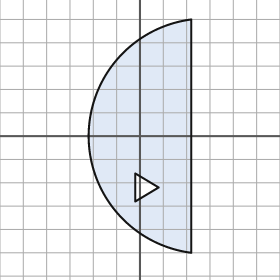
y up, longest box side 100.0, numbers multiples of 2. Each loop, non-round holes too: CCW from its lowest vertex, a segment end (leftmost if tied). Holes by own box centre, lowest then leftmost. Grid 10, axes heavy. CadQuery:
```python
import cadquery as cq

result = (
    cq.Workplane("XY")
    .moveTo(22.0, -50.0)
    .lineTo(22.0, 50.0)
    .threePointArc((-22.0, 0.0), (22.0, -50.0))
    .close()
    .moveTo(-2.0, -28.0)
    .lineTo(8.0, -22.0)
    .lineTo(-2.0, -16.0)
    .close()
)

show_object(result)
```